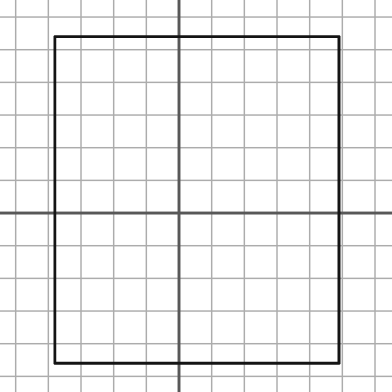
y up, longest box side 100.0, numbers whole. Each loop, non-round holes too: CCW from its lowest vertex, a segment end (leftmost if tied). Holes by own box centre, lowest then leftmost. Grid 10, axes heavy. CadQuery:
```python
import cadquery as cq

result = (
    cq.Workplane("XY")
    .moveTo(-38.0, -46.0)
    .lineTo(49.0, -46.0)
    .lineTo(49.0, 54.0)
    .lineTo(-38.0, 54.0)
    .close()
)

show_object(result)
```